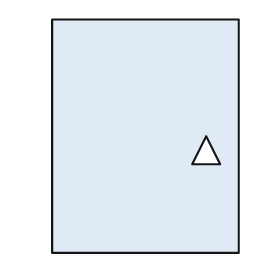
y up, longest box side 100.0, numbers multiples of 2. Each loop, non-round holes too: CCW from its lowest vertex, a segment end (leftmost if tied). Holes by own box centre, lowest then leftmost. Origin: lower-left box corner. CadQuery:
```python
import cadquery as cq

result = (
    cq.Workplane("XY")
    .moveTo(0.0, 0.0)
    .lineTo(80.0, 0.0)
    .lineTo(80.0, 100.0)
    .lineTo(0.0, 100.0)
    .close()
    .moveTo(60.0, 38.0)
    .lineTo(72.0, 38.0)
    .lineTo(66.0, 50.0)
    .close()
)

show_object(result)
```